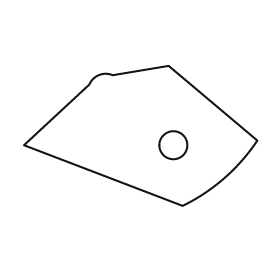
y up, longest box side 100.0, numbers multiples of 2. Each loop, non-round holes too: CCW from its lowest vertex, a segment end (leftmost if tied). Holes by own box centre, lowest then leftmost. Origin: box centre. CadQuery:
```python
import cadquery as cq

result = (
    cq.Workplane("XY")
    .moveTo(18.0, -30.0)
    .threePointArc((36.0, -18.0), (50.0, -2.0))
    .lineTo(12.0, 30.0)
    .lineTo(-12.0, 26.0)
    .threePointArc((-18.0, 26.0), (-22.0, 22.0))
    .lineTo(-50.0, -4.0)
    .close()
    .moveTo(14.0, -4.0)
    .circle(6.0)
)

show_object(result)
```